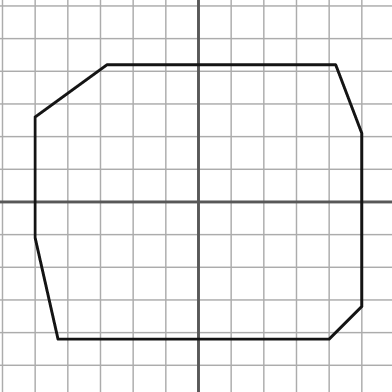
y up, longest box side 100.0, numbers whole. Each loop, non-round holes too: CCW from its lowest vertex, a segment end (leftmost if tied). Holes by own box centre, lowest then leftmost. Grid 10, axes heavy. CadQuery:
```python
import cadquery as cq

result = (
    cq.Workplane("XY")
    .moveTo(-43.0, -42.0)
    .lineTo(40.0, -42.0)
    .lineTo(50.0, -32.0)
    .lineTo(50.0, 21.0)
    .lineTo(42.0, 42.0)
    .lineTo(-28.0, 42.0)
    .lineTo(-50.0, 26.0)
    .lineTo(-50.0, -11.0)
    .close()
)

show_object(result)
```